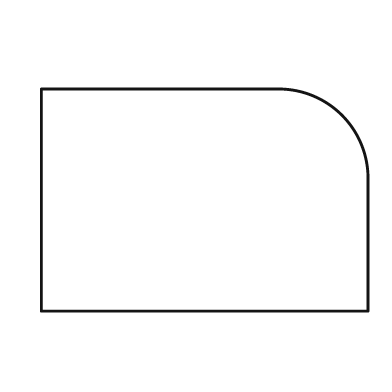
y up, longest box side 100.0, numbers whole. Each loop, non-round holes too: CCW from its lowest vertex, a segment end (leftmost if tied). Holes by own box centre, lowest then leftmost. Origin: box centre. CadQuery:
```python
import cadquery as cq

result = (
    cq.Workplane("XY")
    .moveTo(-50.0, -34.0)
    .lineTo(50.0, -34.0)
    .lineTo(50.0, 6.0)
    .threePointArc((42.0, 26.0), (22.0, 34.0))
    .lineTo(-50.0, 34.0)
    .close()
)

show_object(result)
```